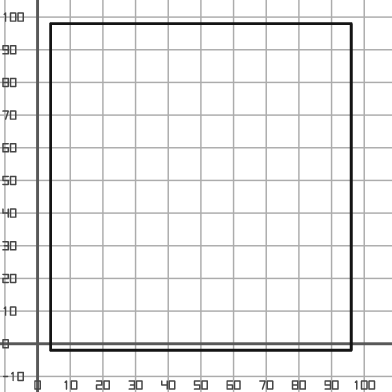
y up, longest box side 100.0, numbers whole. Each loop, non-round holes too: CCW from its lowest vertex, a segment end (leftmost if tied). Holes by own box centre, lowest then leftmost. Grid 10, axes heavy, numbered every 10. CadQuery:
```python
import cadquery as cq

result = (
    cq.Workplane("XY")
    .moveTo(4.0, -2.0)
    .lineTo(96.0, -2.0)
    .lineTo(96.0, 98.0)
    .lineTo(4.0, 98.0)
    .close()
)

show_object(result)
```